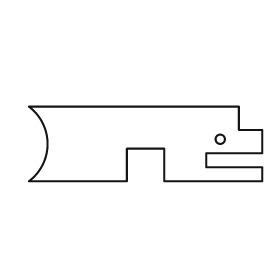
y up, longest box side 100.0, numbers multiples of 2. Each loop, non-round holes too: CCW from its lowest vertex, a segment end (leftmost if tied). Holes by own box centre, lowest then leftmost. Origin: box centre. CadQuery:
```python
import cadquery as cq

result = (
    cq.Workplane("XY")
    .moveTo(-50.0, -16.0)
    .lineTo(-8.0, -16.0)
    .lineTo(-8.0, -2.0)
    .lineTo(8.0, -2.0)
    .lineTo(8.0, -16.0)
    .lineTo(50.0, -16.0)
    .lineTo(50.0, -10.0)
    .lineTo(26.0, -10.0)
    .lineTo(26.0, -4.0)
    .lineTo(50.0, -4.0)
    .lineTo(50.0, 6.0)
    .lineTo(40.0, 6.0)
    .lineTo(40.0, 16.0)
    .lineTo(-50.0, 16.0)
    .threePointArc((-42.0, 0.0), (-50.0, -16.0))
    .close()
    .moveTo(32.0, 2.0)
    .circle(2.0)
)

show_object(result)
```